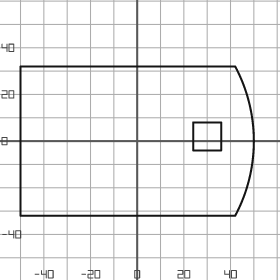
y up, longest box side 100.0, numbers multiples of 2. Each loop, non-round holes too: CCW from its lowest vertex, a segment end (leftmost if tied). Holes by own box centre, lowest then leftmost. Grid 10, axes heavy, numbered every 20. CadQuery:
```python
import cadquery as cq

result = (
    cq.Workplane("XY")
    .moveTo(-50.0, -32.0)
    .lineTo(42.0, -32.0)
    .threePointArc((50.0, 0.0), (42.0, 32.0))
    .lineTo(-50.0, 32.0)
    .close()
    .moveTo(24.0, -4.0)
    .lineTo(36.0, -4.0)
    .lineTo(36.0, 8.0)
    .lineTo(24.0, 8.0)
    .close()
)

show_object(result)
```